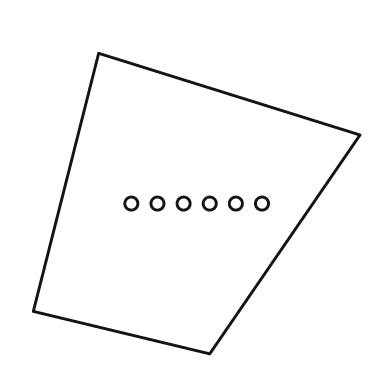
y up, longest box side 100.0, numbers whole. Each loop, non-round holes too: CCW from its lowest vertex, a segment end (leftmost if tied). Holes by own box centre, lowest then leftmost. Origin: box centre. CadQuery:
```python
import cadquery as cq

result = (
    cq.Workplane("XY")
    .moveTo(4.0, -46.0)
    .lineTo(50.0, 21.0)
    .lineTo(-30.0, 46.0)
    .lineTo(-50.0, -33.0)
    .close()
    .moveTo(-20.0, 0.0)
    .circle(2.0)
    .moveTo(-12.0, 0.0)
    .circle(2.0)
    .moveTo(-4.0, 0.0)
    .circle(2.0)
    .moveTo(4.0, 0.0)
    .circle(2.0)
    .moveTo(12.0, 0.0)
    .circle(2.0)
    .moveTo(20.0, 0.0)
    .circle(2.0)
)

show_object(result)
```